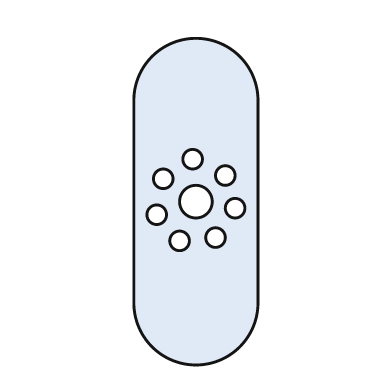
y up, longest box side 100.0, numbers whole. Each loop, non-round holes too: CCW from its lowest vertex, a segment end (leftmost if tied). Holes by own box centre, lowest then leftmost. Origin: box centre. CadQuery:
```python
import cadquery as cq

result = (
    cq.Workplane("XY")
    .moveTo(-19.0, -31.0)
    .threePointArc((0.0, -50.0), (19.0, -31.0))
    .lineTo(19.0, 31.0)
    .threePointArc((0.0, 50.0), (-19.0, 31.0))
    .close()
    .moveTo(-5.0, -12.0)
    .circle(3.0)
    .moveTo(6.0, -11.0)
    .circle(3.0)
    .moveTo(-12.0, -4.0)
    .circle(3.0)
    .moveTo(12.0, -2.0)
    .circle(3.0)
    .moveTo(0.0, 0.0)
    .circle(5.0)
    .moveTo(-10.0, 7.0)
    .circle(3.0)
    .moveTo(9.0, 8.0)
    .circle(3.0)
    .moveTo(-1.0, 13.0)
    .circle(3.0)
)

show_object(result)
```